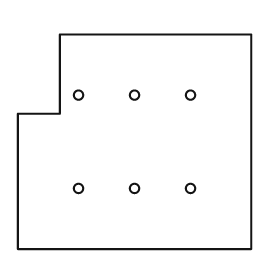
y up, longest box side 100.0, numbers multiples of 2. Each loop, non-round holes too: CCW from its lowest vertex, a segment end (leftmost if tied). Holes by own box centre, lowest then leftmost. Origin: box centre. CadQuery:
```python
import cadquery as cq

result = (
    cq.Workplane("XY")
    .moveTo(-50.0, -46.0)
    .lineTo(50.0, -46.0)
    .lineTo(50.0, 46.0)
    .lineTo(-32.0, 46.0)
    .lineTo(-32.0, 12.0)
    .lineTo(-50.0, 12.0)
    .close()
    .moveTo(-24.0, -20.0)
    .circle(2.0)
    .moveTo(0.0, -20.0)
    .circle(2.0)
    .moveTo(24.0, -20.0)
    .circle(2.0)
    .moveTo(-24.0, 20.0)
    .circle(2.0)
    .moveTo(0.0, 20.0)
    .circle(2.0)
    .moveTo(24.0, 20.0)
    .circle(2.0)
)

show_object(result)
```